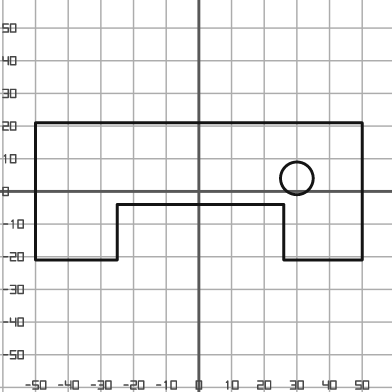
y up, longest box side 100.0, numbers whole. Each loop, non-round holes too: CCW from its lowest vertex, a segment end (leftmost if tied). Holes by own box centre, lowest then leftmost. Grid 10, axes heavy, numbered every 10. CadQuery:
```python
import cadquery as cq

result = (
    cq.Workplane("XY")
    .moveTo(-50.0, -21.0)
    .lineTo(-25.0, -21.0)
    .lineTo(-25.0, -4.0)
    .lineTo(26.0, -4.0)
    .lineTo(26.0, -21.0)
    .lineTo(50.0, -21.0)
    .lineTo(50.0, 21.0)
    .lineTo(-50.0, 21.0)
    .close()
    .moveTo(30.0, 4.0)
    .circle(5.0)
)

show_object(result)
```